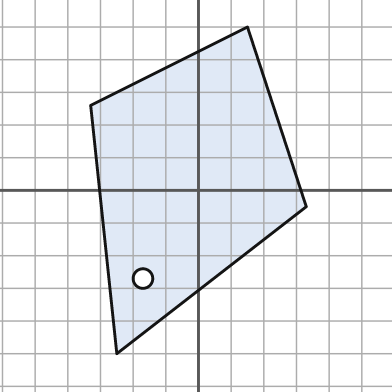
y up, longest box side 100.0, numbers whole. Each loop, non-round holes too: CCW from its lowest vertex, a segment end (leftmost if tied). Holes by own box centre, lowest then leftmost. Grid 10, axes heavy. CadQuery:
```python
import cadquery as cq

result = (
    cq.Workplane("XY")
    .moveTo(-25.0, -50.0)
    .lineTo(33.0, -5.0)
    .lineTo(15.0, 50.0)
    .lineTo(-33.0, 26.0)
    .close()
    .moveTo(-17.0, -27.0)
    .circle(3.0)
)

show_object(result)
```